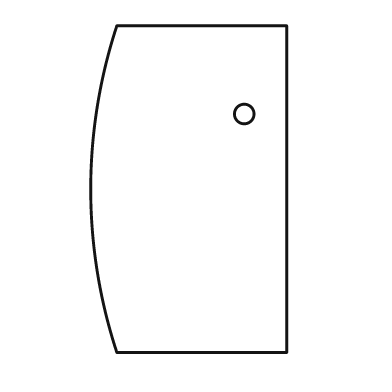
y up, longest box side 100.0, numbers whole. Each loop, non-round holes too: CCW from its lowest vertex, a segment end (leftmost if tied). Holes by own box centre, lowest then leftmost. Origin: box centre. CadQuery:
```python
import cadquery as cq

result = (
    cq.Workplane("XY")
    .moveTo(-22.0, -50.0)
    .lineTo(30.0, -50.0)
    .lineTo(30.0, 50.0)
    .lineTo(-22.0, 50.0)
    .threePointArc((-30.0, 0.0), (-22.0, -50.0))
    .close()
    .moveTo(17.0, 23.0)
    .circle(3.0)
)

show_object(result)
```